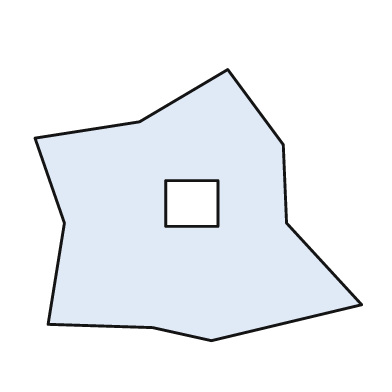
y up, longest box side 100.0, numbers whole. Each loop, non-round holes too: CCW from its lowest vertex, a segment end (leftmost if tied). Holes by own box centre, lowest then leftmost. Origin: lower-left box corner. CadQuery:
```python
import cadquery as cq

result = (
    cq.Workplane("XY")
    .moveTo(54.0, 0.0)
    .lineTo(100.0, 11.0)
    .lineTo(77.0, 36.0)
    .lineTo(76.0, 60.0)
    .lineTo(59.0, 83.0)
    .lineTo(32.0, 67.0)
    .lineTo(0.0, 62.0)
    .lineTo(9.0, 36.0)
    .lineTo(4.0, 5.0)
    .lineTo(36.0, 4.0)
    .close()
    .moveTo(40.0, 35.0)
    .lineTo(56.0, 35.0)
    .lineTo(56.0, 49.0)
    .lineTo(40.0, 49.0)
    .close()
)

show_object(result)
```